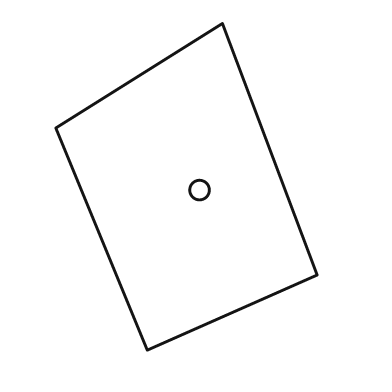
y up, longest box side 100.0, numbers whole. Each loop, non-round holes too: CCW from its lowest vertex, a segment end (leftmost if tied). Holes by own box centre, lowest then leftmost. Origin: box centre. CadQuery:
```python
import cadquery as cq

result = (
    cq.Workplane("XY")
    .moveTo(-12.0, -50.0)
    .lineTo(40.0, -27.0)
    .lineTo(11.0, 50.0)
    .lineTo(-40.0, 18.0)
    .close()
    .moveTo(4.0, -1.0)
    .circle(3.0)
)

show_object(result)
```